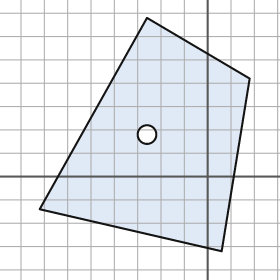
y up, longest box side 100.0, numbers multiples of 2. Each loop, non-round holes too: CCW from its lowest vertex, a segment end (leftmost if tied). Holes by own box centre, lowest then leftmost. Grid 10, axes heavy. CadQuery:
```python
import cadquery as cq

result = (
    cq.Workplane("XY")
    .moveTo(6.0, -32.0)
    .lineTo(18.0, 42.0)
    .lineTo(-26.0, 68.0)
    .lineTo(-72.0, -14.0)
    .close()
    .moveTo(-26.0, 18.0)
    .circle(4.0)
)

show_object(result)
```